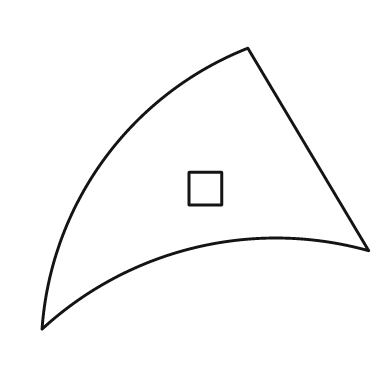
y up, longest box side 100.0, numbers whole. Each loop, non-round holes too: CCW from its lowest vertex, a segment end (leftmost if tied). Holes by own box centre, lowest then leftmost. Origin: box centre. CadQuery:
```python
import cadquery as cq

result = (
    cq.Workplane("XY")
    .moveTo(-50.0, -43.0)
    .threePointArc((-3.0, -18.0), (50.0, -19.0))
    .lineTo(13.0, 43.0)
    .threePointArc((-31.0, 9.0), (-50.0, -43.0))
    .close()
    .moveTo(-5.0, -5.0)
    .lineTo(5.0, -5.0)
    .lineTo(5.0, 5.0)
    .lineTo(-5.0, 5.0)
    .close()
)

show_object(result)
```